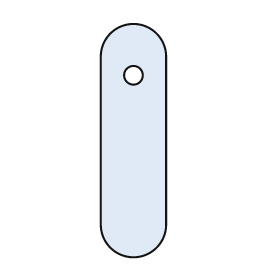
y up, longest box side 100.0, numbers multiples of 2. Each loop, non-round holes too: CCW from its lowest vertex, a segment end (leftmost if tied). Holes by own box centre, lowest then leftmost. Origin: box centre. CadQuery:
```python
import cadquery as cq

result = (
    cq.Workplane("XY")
    .moveTo(-14.0, -36.0)
    .threePointArc((0.0, -50.0), (14.0, -36.0))
    .lineTo(14.0, 36.0)
    .threePointArc((0.0, 50.0), (-14.0, 36.0))
    .close()
    .moveTo(0.0, 28.0)
    .circle(4.0)
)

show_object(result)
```